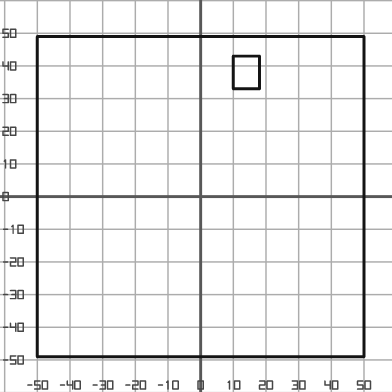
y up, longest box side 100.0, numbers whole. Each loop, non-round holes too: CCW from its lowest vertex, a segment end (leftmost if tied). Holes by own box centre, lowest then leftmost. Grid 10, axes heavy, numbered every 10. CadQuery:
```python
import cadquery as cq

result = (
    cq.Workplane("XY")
    .moveTo(-50.0, -49.0)
    .lineTo(50.0, -49.0)
    .lineTo(50.0, 49.0)
    .lineTo(-50.0, 49.0)
    .close()
    .moveTo(10.0, 33.0)
    .lineTo(18.0, 33.0)
    .lineTo(18.0, 43.0)
    .lineTo(10.0, 43.0)
    .close()
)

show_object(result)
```